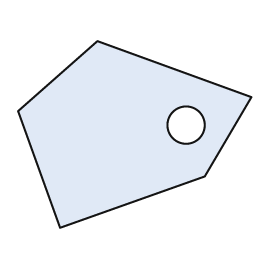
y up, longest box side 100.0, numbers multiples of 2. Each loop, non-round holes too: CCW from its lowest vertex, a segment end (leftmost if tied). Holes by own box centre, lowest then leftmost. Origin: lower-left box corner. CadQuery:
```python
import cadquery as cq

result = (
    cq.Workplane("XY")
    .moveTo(18.0, 0.0)
    .lineTo(80.0, 22.0)
    .lineTo(100.0, 56.0)
    .lineTo(34.0, 80.0)
    .lineTo(0.0, 50.0)
    .close()
    .moveTo(72.0, 44.0)
    .circle(8.0)
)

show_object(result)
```